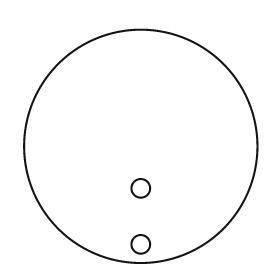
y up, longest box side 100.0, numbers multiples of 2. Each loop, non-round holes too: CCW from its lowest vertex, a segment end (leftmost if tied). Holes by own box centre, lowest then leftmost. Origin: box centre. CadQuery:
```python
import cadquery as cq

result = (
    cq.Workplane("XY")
    .moveTo(0.0, 0.0)
    .circle(50.0)
    .moveTo(0.0, -42.0)
    .circle(4.0)
    .moveTo(0.0, -18.0)
    .circle(4.0)
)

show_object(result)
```